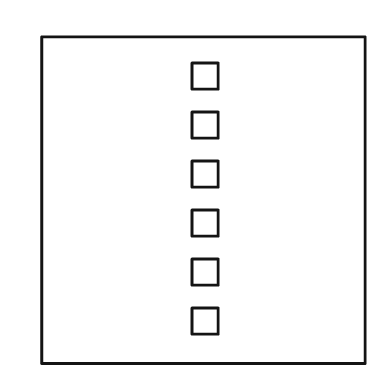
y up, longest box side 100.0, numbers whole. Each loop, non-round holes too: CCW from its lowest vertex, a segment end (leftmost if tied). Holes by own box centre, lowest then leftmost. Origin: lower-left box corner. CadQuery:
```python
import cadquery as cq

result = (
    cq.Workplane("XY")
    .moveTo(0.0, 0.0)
    .lineTo(99.0, 0.0)
    .lineTo(99.0, 100.0)
    .lineTo(0.0, 100.0)
    .close()
    .moveTo(46.0, 9.0)
    .lineTo(54.0, 9.0)
    .lineTo(54.0, 17.0)
    .lineTo(46.0, 17.0)
    .close()
    .moveTo(46.0, 24.0)
    .lineTo(54.0, 24.0)
    .lineTo(54.0, 32.0)
    .lineTo(46.0, 32.0)
    .close()
    .moveTo(46.0, 39.0)
    .lineTo(54.0, 39.0)
    .lineTo(54.0, 47.0)
    .lineTo(46.0, 47.0)
    .close()
    .moveTo(46.0, 54.0)
    .lineTo(54.0, 54.0)
    .lineTo(54.0, 62.0)
    .lineTo(46.0, 62.0)
    .close()
    .moveTo(46.0, 69.0)
    .lineTo(54.0, 69.0)
    .lineTo(54.0, 77.0)
    .lineTo(46.0, 77.0)
    .close()
    .moveTo(46.0, 84.0)
    .lineTo(54.0, 84.0)
    .lineTo(54.0, 92.0)
    .lineTo(46.0, 92.0)
    .close()
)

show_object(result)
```